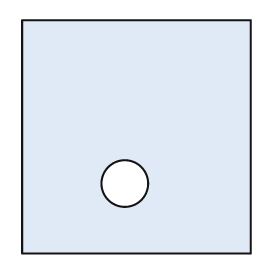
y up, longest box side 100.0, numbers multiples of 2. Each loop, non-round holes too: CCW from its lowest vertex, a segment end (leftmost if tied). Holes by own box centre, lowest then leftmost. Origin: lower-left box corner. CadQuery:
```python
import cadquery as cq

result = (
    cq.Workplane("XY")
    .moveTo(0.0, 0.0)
    .lineTo(98.0, 0.0)
    .lineTo(98.0, 100.0)
    .lineTo(0.0, 100.0)
    .close()
    .moveTo(44.0, 30.0)
    .circle(10.0)
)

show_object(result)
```